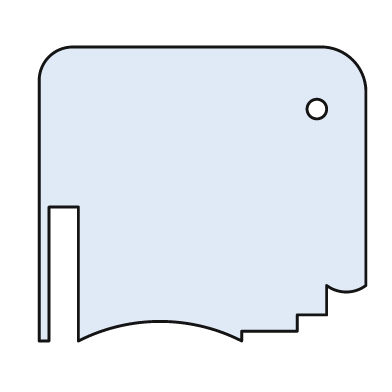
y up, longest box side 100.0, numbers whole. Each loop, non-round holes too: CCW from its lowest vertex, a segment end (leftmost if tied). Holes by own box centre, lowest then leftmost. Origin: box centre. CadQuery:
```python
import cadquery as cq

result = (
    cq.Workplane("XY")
    .moveTo(-50.0, -45.0)
    .lineTo(-47.0, -45.0)
    .lineTo(-47.0, -4.0)
    .lineTo(-38.0, -4.0)
    .lineTo(-38.0, -45.0)
    .threePointArc((-13.0, -39.0), (12.0, -45.0))
    .lineTo(12.0, -42.0)
    .lineTo(29.0, -42.0)
    .lineTo(29.0, -37.0)
    .lineTo(38.0, -37.0)
    .lineTo(38.0, -28.0)
    .threePointArc((44.0, -30.0), (50.0, -28.0))
    .lineTo(50.0, 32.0)
    .threePointArc((46.0, 41.0), (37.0, 45.0))
    .lineTo(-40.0, 45.0)
    .threePointArc((-47.0, 42.0), (-50.0, 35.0))
    .close()
    .moveTo(35.0, 26.0)
    .circle(3.0)
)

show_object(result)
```